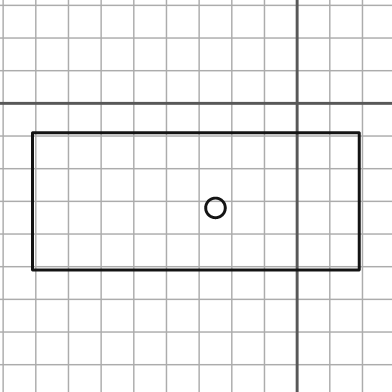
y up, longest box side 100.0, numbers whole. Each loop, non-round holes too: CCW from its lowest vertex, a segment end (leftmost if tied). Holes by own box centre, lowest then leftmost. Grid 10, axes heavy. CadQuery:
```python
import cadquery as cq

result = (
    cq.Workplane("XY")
    .moveTo(-81.0, -51.0)
    .lineTo(19.0, -51.0)
    .lineTo(19.0, -9.0)
    .lineTo(-81.0, -9.0)
    .close()
    .moveTo(-25.0, -32.0)
    .circle(3.0)
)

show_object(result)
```